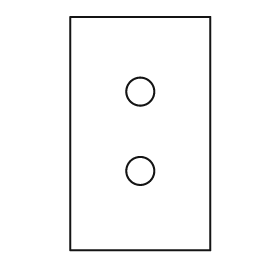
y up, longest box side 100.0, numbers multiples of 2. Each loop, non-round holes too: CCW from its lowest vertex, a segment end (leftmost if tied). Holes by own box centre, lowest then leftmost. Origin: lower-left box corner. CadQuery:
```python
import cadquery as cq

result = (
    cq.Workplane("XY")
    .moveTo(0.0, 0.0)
    .lineTo(60.0, 0.0)
    .lineTo(60.0, 100.0)
    .lineTo(0.0, 100.0)
    .close()
    .moveTo(30.0, 34.0)
    .circle(6.0)
    .moveTo(30.0, 68.0)
    .circle(6.0)
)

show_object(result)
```